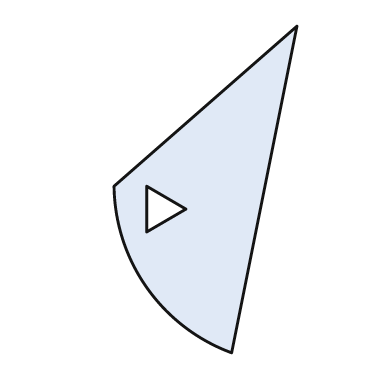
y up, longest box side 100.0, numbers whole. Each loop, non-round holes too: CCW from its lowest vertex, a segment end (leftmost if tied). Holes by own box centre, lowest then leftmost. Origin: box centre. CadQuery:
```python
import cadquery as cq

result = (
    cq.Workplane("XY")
    .moveTo(8.0, -50.0)
    .lineTo(28.0, 50.0)
    .lineTo(-28.0, 1.0)
    .threePointArc((-18.0, -30.0), (8.0, -50.0))
    .close()
    .moveTo(-18.0, -13.0)
    .lineTo(-6.0, -6.0)
    .lineTo(-18.0, 1.0)
    .close()
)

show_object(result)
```